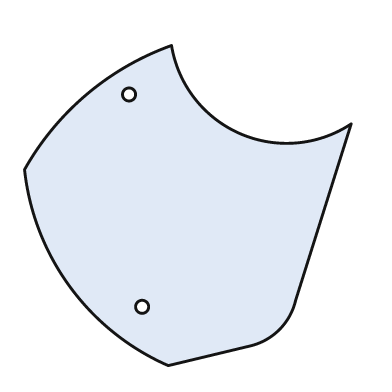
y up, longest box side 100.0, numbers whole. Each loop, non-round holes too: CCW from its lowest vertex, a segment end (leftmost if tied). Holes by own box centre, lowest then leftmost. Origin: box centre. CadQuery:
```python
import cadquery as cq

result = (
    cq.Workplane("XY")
    .moveTo(-6.0, -49.0)
    .lineTo(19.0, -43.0)
    .threePointArc((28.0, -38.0), (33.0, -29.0))
    .lineTo(50.0, 25.0)
    .threePointArc((16.0, 22.0), (-5.0, 49.0))
    .threePointArc((-31.0, 34.0), (-50.0, 11.0))
    .threePointArc((-36.0, -25.0), (-6.0, -49.0))
    .close()
    .moveTo(-14.0, -31.0)
    .circle(2.0)
    .moveTo(-18.0, 34.0)
    .circle(2.0)
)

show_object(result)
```